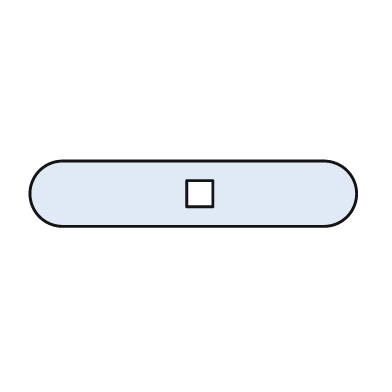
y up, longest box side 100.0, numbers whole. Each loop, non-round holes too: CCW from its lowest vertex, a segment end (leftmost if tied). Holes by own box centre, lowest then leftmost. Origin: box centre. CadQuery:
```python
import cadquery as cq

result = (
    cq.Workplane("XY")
    .moveTo(-40.0, -10.0)
    .lineTo(40.0, -10.0)
    .threePointArc((50.0, 0.0), (40.0, 10.0))
    .lineTo(-40.0, 10.0)
    .threePointArc((-50.0, 0.0), (-40.0, -10.0))
    .close()
    .moveTo(-2.0, -4.0)
    .lineTo(6.0, -4.0)
    .lineTo(6.0, 4.0)
    .lineTo(-2.0, 4.0)
    .close()
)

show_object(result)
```